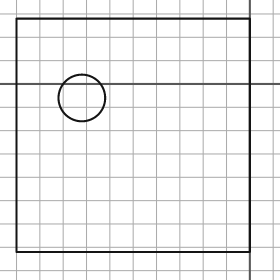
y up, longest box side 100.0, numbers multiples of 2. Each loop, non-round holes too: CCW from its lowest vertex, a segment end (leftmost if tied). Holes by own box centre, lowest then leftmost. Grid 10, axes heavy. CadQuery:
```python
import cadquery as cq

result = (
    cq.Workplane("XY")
    .moveTo(-100.0, -72.0)
    .lineTo(0.0, -72.0)
    .lineTo(0.0, 28.0)
    .lineTo(-100.0, 28.0)
    .close()
    .moveTo(-72.0, -6.0)
    .circle(10.0)
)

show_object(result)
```